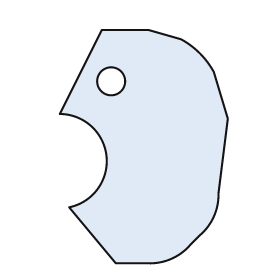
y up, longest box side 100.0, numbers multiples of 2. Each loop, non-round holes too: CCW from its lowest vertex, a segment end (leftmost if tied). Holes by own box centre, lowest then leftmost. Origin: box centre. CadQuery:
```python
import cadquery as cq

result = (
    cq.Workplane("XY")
    .moveTo(-12.0, -50.0)
    .lineTo(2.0, -50.0)
    .threePointArc((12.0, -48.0), (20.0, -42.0))
    .lineTo(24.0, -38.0)
    .threePointArc((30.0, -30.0), (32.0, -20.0))
    .lineTo(36.0, 12.0)
    .lineTo(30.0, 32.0)
    .threePointArc((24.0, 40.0), (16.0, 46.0))
    .lineTo(2.0, 50.0)
    .lineTo(-18.0, 50.0)
    .lineTo(-36.0, 14.0)
    .threePointArc((-16.0, -4.0), (-32.0, -26.0))
    .close()
    .moveTo(-14.0, 28.0)
    .circle(6.0)
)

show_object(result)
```